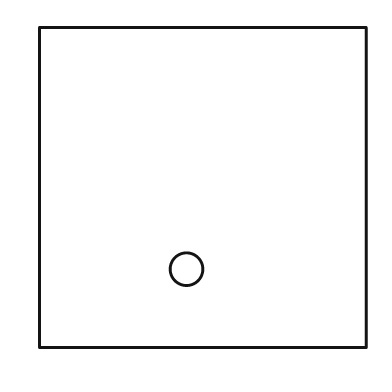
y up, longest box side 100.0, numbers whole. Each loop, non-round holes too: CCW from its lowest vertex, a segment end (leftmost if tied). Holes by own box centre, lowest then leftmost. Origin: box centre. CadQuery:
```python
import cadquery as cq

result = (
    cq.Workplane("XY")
    .moveTo(-50.0, -49.0)
    .lineTo(50.0, -49.0)
    .lineTo(50.0, 49.0)
    .lineTo(-50.0, 49.0)
    .close()
    .moveTo(-5.0, -25.0)
    .circle(5.0)
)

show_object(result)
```